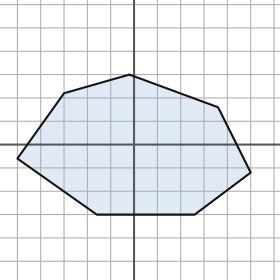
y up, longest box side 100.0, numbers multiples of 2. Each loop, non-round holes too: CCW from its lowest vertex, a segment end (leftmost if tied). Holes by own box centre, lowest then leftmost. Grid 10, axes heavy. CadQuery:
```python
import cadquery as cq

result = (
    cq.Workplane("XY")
    .moveTo(-16.0, -30.0)
    .lineTo(26.0, -30.0)
    .lineTo(50.0, -12.0)
    .lineTo(36.0, 16.0)
    .lineTo(-2.0, 30.0)
    .lineTo(-30.0, 22.0)
    .lineTo(-50.0, -6.0)
    .close()
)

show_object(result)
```